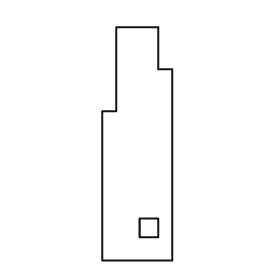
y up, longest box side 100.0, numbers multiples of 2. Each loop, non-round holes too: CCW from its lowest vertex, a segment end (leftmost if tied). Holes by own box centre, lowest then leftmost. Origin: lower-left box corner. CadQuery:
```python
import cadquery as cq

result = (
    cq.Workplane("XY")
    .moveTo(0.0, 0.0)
    .lineTo(30.0, 0.0)
    .lineTo(30.0, 82.0)
    .lineTo(24.0, 82.0)
    .lineTo(24.0, 100.0)
    .lineTo(6.0, 100.0)
    .lineTo(6.0, 64.0)
    .lineTo(0.0, 64.0)
    .close()
    .moveTo(16.0, 10.0)
    .lineTo(24.0, 10.0)
    .lineTo(24.0, 18.0)
    .lineTo(16.0, 18.0)
    .close()
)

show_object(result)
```